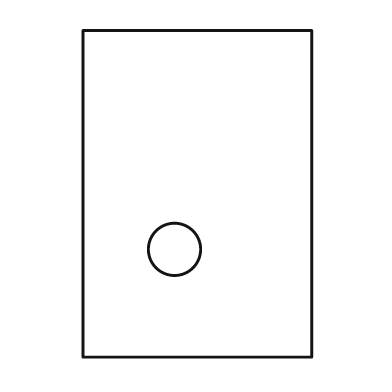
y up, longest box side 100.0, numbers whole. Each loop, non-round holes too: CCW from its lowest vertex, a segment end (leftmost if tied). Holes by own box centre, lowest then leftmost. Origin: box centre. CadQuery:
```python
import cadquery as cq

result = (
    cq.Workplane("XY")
    .moveTo(-35.0, -50.0)
    .lineTo(35.0, -50.0)
    .lineTo(35.0, 50.0)
    .lineTo(-35.0, 50.0)
    .close()
    .moveTo(-7.0, -17.0)
    .circle(8.0)
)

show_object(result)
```